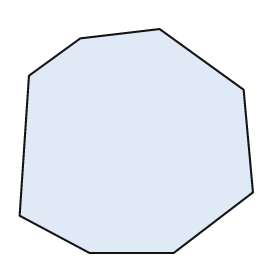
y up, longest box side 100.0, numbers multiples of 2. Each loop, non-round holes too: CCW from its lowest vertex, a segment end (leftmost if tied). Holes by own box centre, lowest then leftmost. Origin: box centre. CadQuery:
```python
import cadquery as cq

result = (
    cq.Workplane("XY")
    .moveTo(-20.0, -48.0)
    .lineTo(16.0, -48.0)
    .lineTo(50.0, -22.0)
    .lineTo(46.0, 22.0)
    .lineTo(10.0, 48.0)
    .lineTo(-24.0, 44.0)
    .lineTo(-46.0, 28.0)
    .lineTo(-50.0, -32.0)
    .close()
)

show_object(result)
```